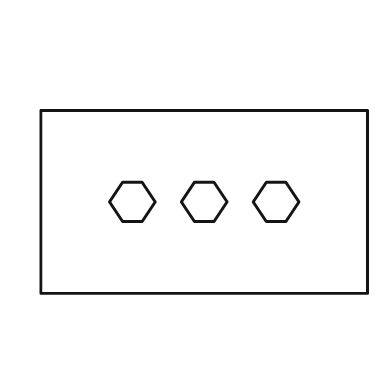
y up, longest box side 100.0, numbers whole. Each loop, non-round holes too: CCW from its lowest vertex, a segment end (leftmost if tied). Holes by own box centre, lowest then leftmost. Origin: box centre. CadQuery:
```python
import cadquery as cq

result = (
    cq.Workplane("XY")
    .moveTo(-50.0, -28.0)
    .lineTo(50.0, -28.0)
    .lineTo(50.0, 28.0)
    .lineTo(-50.0, 28.0)
    .close()
    .moveTo(-25.0, -6.0)
    .lineTo(-19.0, -6.0)
    .lineTo(-15.0, 0.0)
    .lineTo(-19.0, 6.0)
    .lineTo(-25.0, 6.0)
    .lineTo(-29.0, 0.0)
    .close()
    .moveTo(-3.0, -6.0)
    .lineTo(3.0, -6.0)
    .lineTo(7.0, 0.0)
    .lineTo(3.0, 6.0)
    .lineTo(-3.0, 6.0)
    .lineTo(-7.0, 0.0)
    .close()
    .moveTo(19.0, -6.0)
    .lineTo(25.0, -6.0)
    .lineTo(29.0, 0.0)
    .lineTo(25.0, 6.0)
    .lineTo(19.0, 6.0)
    .lineTo(15.0, 0.0)
    .close()
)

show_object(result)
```